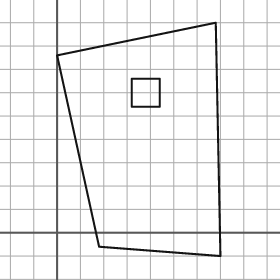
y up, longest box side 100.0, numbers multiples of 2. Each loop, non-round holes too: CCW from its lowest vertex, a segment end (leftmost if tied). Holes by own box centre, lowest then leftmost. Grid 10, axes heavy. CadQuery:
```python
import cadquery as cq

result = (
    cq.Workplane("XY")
    .moveTo(70.0, -10.0)
    .lineTo(68.0, 90.0)
    .lineTo(0.0, 76.0)
    .lineTo(18.0, -6.0)
    .close()
    .moveTo(32.0, 54.0)
    .lineTo(44.0, 54.0)
    .lineTo(44.0, 66.0)
    .lineTo(32.0, 66.0)
    .close()
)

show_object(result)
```